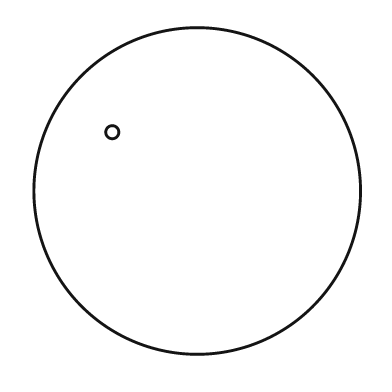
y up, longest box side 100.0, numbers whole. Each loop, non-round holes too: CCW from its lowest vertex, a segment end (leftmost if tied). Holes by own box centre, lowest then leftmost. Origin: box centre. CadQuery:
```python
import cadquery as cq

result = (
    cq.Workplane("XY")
    .moveTo(0.0, 0.0)
    .circle(50.0)
    .moveTo(-26.0, 18.0)
    .circle(2.0)
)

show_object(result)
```